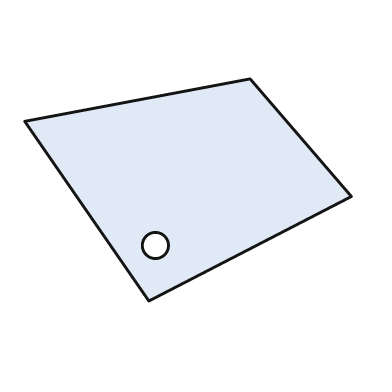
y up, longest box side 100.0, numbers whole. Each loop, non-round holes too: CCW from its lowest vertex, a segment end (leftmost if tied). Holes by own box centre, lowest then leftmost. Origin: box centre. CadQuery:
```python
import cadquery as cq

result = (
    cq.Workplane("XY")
    .moveTo(-12.0, -34.0)
    .lineTo(50.0, -2.0)
    .lineTo(19.0, 34.0)
    .lineTo(-50.0, 21.0)
    .close()
    .moveTo(-10.0, -17.0)
    .circle(4.0)
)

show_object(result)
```